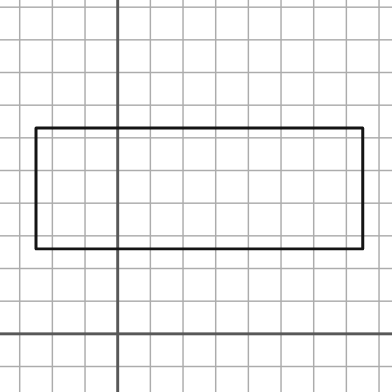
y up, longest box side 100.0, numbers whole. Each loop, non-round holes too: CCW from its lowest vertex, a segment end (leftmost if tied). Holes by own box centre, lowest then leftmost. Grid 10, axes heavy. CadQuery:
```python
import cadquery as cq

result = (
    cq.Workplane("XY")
    .moveTo(-25.0, 26.0)
    .lineTo(75.0, 26.0)
    .lineTo(75.0, 63.0)
    .lineTo(-25.0, 63.0)
    .close()
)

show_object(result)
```